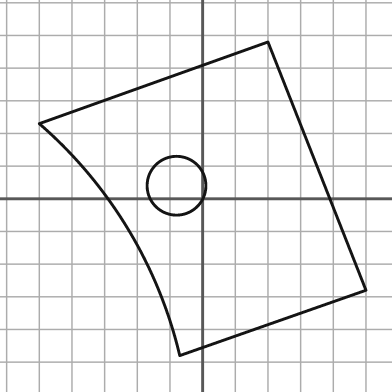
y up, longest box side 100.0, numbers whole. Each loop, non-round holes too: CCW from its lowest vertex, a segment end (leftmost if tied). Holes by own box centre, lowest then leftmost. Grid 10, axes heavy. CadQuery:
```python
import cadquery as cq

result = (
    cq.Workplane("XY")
    .moveTo(-7.0, -48.0)
    .lineTo(50.0, -28.0)
    .lineTo(20.0, 48.0)
    .lineTo(-50.0, 23.0)
    .threePointArc((-23.0, -9.0), (-7.0, -48.0))
    .close()
    .moveTo(-8.0, 4.0)
    .circle(9.0)
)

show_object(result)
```